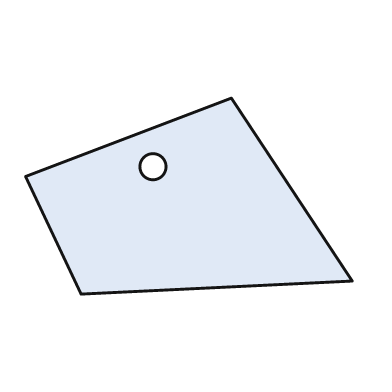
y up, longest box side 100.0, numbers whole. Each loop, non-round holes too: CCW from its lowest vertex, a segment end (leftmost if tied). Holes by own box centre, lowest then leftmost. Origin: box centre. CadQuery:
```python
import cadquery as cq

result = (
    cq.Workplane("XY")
    .moveTo(-33.0, -30.0)
    .lineTo(50.0, -26.0)
    .lineTo(13.0, 30.0)
    .lineTo(-50.0, 6.0)
    .close()
    .moveTo(-11.0, 9.0)
    .circle(4.0)
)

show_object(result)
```